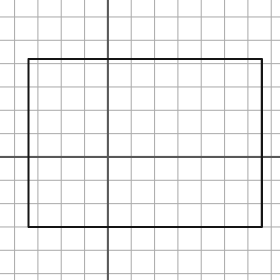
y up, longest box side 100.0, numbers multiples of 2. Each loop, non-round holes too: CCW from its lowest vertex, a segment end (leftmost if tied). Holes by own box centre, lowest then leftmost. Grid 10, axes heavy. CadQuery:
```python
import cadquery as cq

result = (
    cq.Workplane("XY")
    .moveTo(-34.0, -30.0)
    .lineTo(66.0, -30.0)
    .lineTo(66.0, 42.0)
    .lineTo(-34.0, 42.0)
    .close()
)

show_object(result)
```